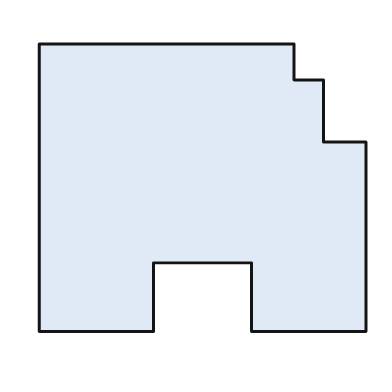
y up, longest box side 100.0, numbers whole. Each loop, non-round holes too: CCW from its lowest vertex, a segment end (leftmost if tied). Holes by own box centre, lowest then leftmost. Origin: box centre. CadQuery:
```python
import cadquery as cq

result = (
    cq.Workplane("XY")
    .moveTo(-50.0, -44.0)
    .lineTo(-15.0, -44.0)
    .lineTo(-15.0, -23.0)
    .lineTo(15.0, -23.0)
    .lineTo(15.0, -44.0)
    .lineTo(50.0, -44.0)
    .lineTo(50.0, 14.0)
    .lineTo(37.0, 14.0)
    .lineTo(37.0, 33.0)
    .lineTo(28.0, 33.0)
    .lineTo(28.0, 44.0)
    .lineTo(-50.0, 44.0)
    .close()
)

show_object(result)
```